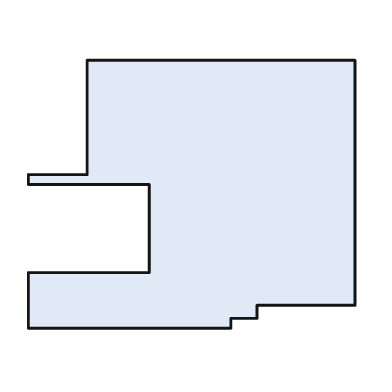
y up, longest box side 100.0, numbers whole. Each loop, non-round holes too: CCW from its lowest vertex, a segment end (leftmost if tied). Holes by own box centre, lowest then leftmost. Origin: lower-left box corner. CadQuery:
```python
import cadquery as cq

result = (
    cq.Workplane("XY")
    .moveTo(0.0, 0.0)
    .lineTo(62.0, 0.0)
    .lineTo(62.0, 3.0)
    .lineTo(70.0, 3.0)
    .lineTo(70.0, 7.0)
    .lineTo(100.0, 7.0)
    .lineTo(100.0, 82.0)
    .lineTo(18.0, 82.0)
    .lineTo(18.0, 47.0)
    .lineTo(0.0, 47.0)
    .lineTo(0.0, 44.0)
    .lineTo(37.0, 44.0)
    .lineTo(37.0, 17.0)
    .lineTo(0.0, 17.0)
    .close()
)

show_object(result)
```